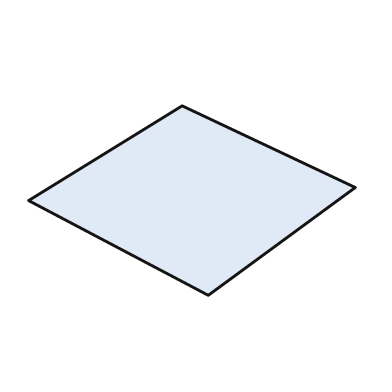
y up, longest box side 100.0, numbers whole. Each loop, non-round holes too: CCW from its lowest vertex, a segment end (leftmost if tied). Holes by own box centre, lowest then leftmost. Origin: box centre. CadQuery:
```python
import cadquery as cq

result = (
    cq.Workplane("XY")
    .moveTo(5.0, -29.0)
    .lineTo(50.0, 4.0)
    .lineTo(-3.0, 29.0)
    .lineTo(-50.0, 0.0)
    .close()
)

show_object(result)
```